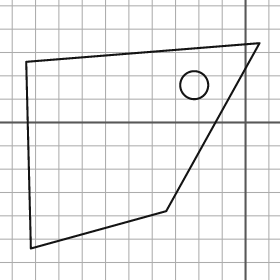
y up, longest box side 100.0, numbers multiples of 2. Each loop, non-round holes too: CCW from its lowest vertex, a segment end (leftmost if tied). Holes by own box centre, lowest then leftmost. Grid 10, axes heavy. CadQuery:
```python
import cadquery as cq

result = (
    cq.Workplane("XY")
    .moveTo(-92.0, -54.0)
    .lineTo(-34.0, -38.0)
    .lineTo(6.0, 34.0)
    .lineTo(-94.0, 26.0)
    .close()
    .moveTo(-22.0, 16.0)
    .circle(6.0)
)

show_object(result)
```